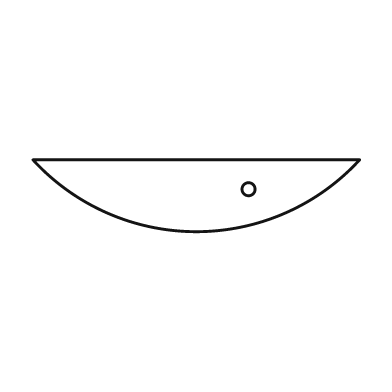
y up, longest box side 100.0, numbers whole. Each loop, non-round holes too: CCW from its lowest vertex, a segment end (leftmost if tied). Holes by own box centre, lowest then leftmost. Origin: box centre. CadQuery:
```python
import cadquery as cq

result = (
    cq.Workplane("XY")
    .moveTo(-50.0, 11.0)
    .threePointArc((0.0, -11.0), (50.0, 11.0))
    .close()
    .moveTo(16.0, 2.0)
    .circle(2.0)
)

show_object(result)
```